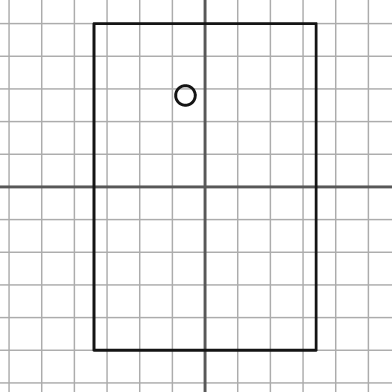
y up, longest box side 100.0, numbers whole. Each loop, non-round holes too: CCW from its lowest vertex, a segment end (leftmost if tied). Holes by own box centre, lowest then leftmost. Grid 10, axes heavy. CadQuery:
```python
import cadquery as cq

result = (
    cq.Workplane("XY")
    .moveTo(-34.0, -50.0)
    .lineTo(34.0, -50.0)
    .lineTo(34.0, 50.0)
    .lineTo(-34.0, 50.0)
    .close()
    .moveTo(-6.0, 28.0)
    .circle(3.0)
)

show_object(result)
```